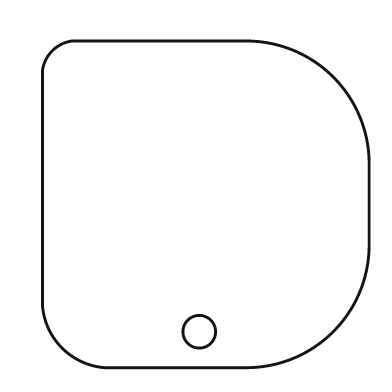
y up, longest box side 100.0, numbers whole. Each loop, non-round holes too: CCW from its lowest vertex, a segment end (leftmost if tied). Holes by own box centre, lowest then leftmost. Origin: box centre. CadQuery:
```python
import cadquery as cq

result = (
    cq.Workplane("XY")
    .moveTo(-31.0, -50.0)
    .lineTo(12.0, -50.0)
    .threePointArc((39.0, -39.0), (50.0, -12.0))
    .lineTo(50.0, 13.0)
    .threePointArc((39.0, 39.0), (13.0, 50.0))
    .lineTo(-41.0, 50.0)
    .threePointArc((-47.0, 47.0), (-50.0, 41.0))
    .lineTo(-50.0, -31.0)
    .threePointArc((-44.0, -44.0), (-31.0, -50.0))
    .close()
    .moveTo(-2.0, -39.0)
    .circle(5.0)
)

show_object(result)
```